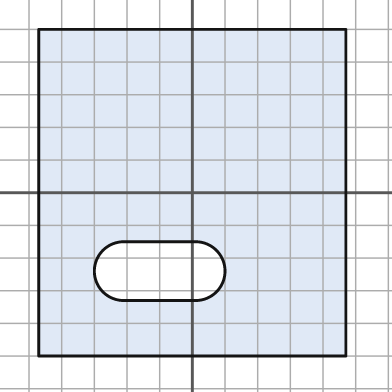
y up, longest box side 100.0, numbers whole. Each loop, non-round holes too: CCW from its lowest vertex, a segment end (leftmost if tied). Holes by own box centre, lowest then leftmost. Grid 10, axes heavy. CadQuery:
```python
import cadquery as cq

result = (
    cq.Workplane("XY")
    .moveTo(-47.0, -50.0)
    .lineTo(47.0, -50.0)
    .lineTo(47.0, 50.0)
    .lineTo(-47.0, 50.0)
    .close()
    .moveTo(-21.0, -33.0)
    .lineTo(1.0, -33.0)
    .threePointArc((10.0, -24.0), (1.0, -15.0))
    .lineTo(-21.0, -15.0)
    .threePointArc((-30.0, -24.0), (-21.0, -33.0))
    .close()
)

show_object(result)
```